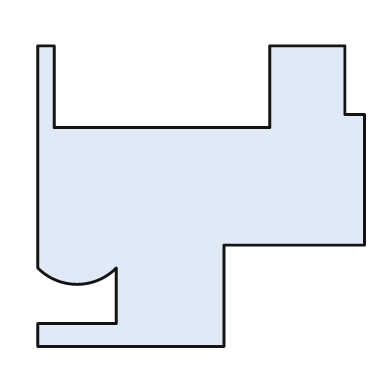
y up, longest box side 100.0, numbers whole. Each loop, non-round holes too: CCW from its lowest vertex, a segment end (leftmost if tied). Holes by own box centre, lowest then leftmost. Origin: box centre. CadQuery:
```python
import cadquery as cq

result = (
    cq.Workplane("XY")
    .moveTo(-50.0, -46.0)
    .lineTo(7.0, -46.0)
    .lineTo(7.0, -15.0)
    .lineTo(50.0, -15.0)
    .lineTo(50.0, 25.0)
    .lineTo(44.0, 25.0)
    .lineTo(44.0, 46.0)
    .lineTo(21.0, 46.0)
    .lineTo(21.0, 21.0)
    .lineTo(-45.0, 21.0)
    .lineTo(-45.0, 46.0)
    .lineTo(-50.0, 46.0)
    .lineTo(-50.0, -22.0)
    .threePointArc((-38.0, -27.0), (-26.0, -22.0))
    .lineTo(-26.0, -39.0)
    .lineTo(-50.0, -39.0)
    .close()
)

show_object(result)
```